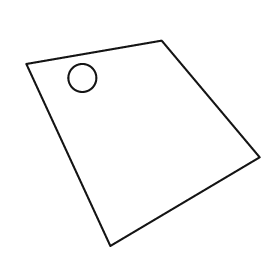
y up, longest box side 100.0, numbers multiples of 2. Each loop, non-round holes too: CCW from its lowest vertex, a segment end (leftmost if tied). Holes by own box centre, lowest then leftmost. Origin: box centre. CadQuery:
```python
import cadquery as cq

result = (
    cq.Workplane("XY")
    .moveTo(-14.0, -44.0)
    .lineTo(50.0, -6.0)
    .lineTo(8.0, 44.0)
    .lineTo(-50.0, 34.0)
    .close()
    .moveTo(-26.0, 28.0)
    .circle(6.0)
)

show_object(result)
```